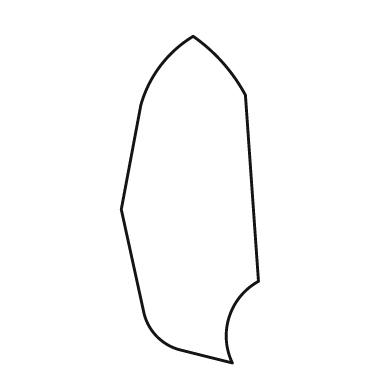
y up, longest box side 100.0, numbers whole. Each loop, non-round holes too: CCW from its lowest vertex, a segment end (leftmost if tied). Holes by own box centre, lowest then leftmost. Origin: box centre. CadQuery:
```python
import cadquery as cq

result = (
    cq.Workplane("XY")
    .moveTo(13.0, -50.0)
    .threePointArc((12.0, -36.0), (21.0, -25.0))
    .lineTo(17.0, 32.0)
    .threePointArc((10.0, 42.0), (1.0, 50.0))
    .threePointArc((-9.0, 41.0), (-15.0, 29.0))
    .lineTo(-21.0, -3.0)
    .lineTo(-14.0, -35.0)
    .threePointArc((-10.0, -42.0), (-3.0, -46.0))
    .close()
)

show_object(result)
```